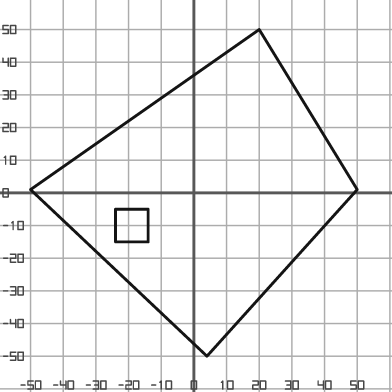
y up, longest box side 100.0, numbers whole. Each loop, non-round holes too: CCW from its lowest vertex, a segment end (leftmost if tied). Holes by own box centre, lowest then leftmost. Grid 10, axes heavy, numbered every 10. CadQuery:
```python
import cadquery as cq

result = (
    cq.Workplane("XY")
    .moveTo(4.0, -50.0)
    .lineTo(50.0, 1.0)
    .lineTo(20.0, 50.0)
    .lineTo(-50.0, 1.0)
    .close()
    .moveTo(-24.0, -15.0)
    .lineTo(-14.0, -15.0)
    .lineTo(-14.0, -5.0)
    .lineTo(-24.0, -5.0)
    .close()
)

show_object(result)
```